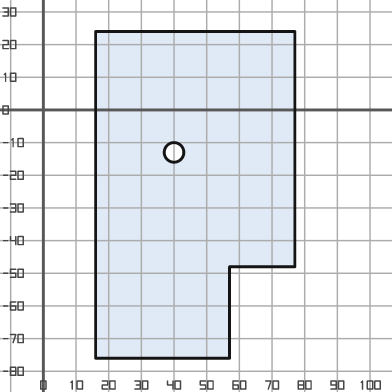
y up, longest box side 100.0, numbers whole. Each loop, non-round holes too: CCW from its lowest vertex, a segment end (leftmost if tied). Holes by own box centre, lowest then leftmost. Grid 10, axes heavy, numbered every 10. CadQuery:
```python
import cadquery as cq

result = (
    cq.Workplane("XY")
    .moveTo(16.0, -76.0)
    .lineTo(57.0, -76.0)
    .lineTo(57.0, -48.0)
    .lineTo(77.0, -48.0)
    .lineTo(77.0, 24.0)
    .lineTo(16.0, 24.0)
    .close()
    .moveTo(40.0, -13.0)
    .circle(3.0)
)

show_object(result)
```